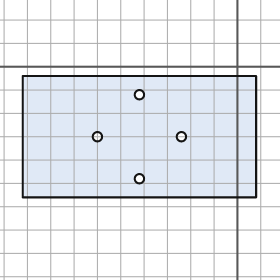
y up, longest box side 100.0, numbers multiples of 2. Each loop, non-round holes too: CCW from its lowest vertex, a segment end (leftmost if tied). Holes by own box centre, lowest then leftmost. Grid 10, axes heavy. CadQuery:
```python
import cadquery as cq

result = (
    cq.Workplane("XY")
    .moveTo(-92.0, -56.0)
    .lineTo(8.0, -56.0)
    .lineTo(8.0, -4.0)
    .lineTo(-92.0, -4.0)
    .close()
    .moveTo(-42.0, -48.0)
    .circle(2.0)
    .moveTo(-60.0, -30.0)
    .circle(2.0)
    .moveTo(-24.0, -30.0)
    .circle(2.0)
    .moveTo(-42.0, -12.0)
    .circle(2.0)
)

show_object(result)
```